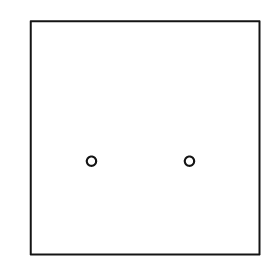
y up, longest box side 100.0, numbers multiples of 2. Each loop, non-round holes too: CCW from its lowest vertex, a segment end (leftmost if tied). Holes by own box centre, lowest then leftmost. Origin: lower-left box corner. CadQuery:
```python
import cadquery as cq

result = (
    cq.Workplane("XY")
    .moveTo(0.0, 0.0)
    .lineTo(98.0, 0.0)
    .lineTo(98.0, 100.0)
    .lineTo(0.0, 100.0)
    .close()
    .moveTo(26.0, 40.0)
    .circle(2.0)
    .moveTo(68.0, 40.0)
    .circle(2.0)
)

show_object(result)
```